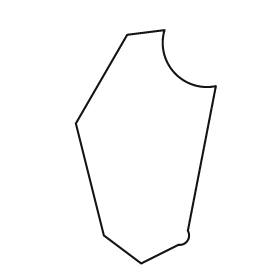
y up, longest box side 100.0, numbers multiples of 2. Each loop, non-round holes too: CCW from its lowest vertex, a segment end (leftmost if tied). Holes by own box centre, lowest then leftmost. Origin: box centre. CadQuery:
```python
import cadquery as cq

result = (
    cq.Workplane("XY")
    .moveTo(-2.0, -50.0)
    .lineTo(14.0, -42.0)
    .threePointArc((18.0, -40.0), (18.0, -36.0))
    .lineTo(30.0, 26.0)
    .threePointArc((12.0, 32.0), (8.0, 50.0))
    .lineTo(-8.0, 48.0)
    .lineTo(-30.0, 10.0)
    .lineTo(-18.0, -38.0)
    .close()
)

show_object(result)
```